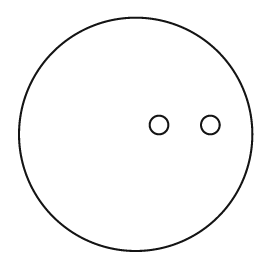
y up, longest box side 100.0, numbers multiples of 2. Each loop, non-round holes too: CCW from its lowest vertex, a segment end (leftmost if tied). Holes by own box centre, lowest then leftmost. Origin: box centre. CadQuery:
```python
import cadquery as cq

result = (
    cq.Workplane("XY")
    .moveTo(0.0, 0.0)
    .circle(50.0)
    .moveTo(10.0, 4.0)
    .circle(4.0)
    .moveTo(32.0, 4.0)
    .circle(4.0)
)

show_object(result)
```